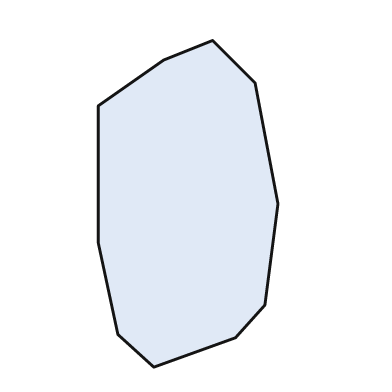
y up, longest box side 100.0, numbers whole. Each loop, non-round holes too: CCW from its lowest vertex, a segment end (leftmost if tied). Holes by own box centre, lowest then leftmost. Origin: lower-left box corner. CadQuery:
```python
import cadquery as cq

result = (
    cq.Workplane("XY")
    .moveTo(17.0, 0.0)
    .lineTo(42.0, 9.0)
    .lineTo(51.0, 19.0)
    .lineTo(55.0, 50.0)
    .lineTo(48.0, 87.0)
    .lineTo(35.0, 100.0)
    .lineTo(20.0, 94.0)
    .lineTo(0.0, 80.0)
    .lineTo(0.0, 38.0)
    .lineTo(6.0, 10.0)
    .close()
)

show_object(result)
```